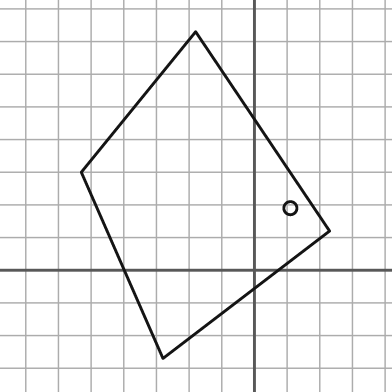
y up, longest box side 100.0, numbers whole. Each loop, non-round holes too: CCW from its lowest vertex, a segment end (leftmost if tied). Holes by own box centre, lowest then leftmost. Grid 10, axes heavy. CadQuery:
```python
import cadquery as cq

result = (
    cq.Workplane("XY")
    .moveTo(-28.0, -27.0)
    .lineTo(23.0, 12.0)
    .lineTo(-18.0, 73.0)
    .lineTo(-53.0, 30.0)
    .close()
    .moveTo(11.0, 19.0)
    .circle(2.0)
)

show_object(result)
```